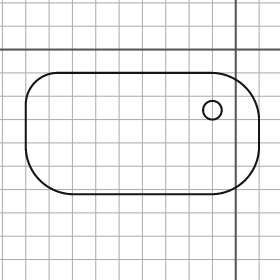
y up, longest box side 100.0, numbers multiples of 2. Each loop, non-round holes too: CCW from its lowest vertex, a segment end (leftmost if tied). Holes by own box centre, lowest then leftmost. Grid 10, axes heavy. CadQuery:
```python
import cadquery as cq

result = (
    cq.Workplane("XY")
    .moveTo(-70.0, -62.0)
    .lineTo(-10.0, -62.0)
    .threePointArc((4.0, -56.0), (10.0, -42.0))
    .lineTo(10.0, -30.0)
    .threePointArc((4.0, -16.0), (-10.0, -10.0))
    .lineTo(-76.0, -10.0)
    .threePointArc((-86.0, -14.0), (-90.0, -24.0))
    .lineTo(-90.0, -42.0)
    .threePointArc((-84.0, -56.0), (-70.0, -62.0))
    .close()
    .moveTo(-10.0, -26.0)
    .circle(4.0)
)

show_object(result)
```